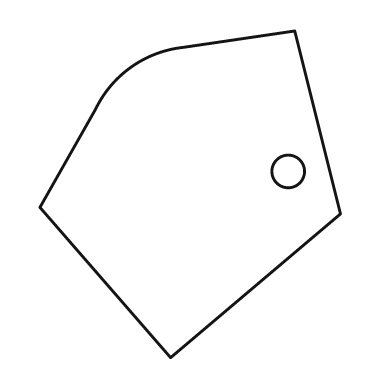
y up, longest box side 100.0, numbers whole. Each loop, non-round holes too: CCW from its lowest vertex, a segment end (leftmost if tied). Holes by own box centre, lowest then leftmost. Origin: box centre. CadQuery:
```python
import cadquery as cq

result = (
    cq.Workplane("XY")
    .moveTo(-6.0, -50.0)
    .lineTo(46.0, -6.0)
    .lineTo(32.0, 50.0)
    .lineTo(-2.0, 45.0)
    .threePointArc((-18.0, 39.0), (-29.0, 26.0))
    .lineTo(-46.0, -4.0)
    .close()
    .moveTo(30.0, 7.0)
    .circle(5.0)
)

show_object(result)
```